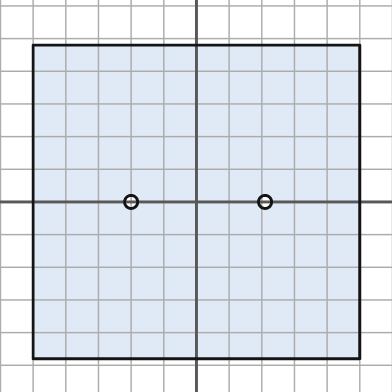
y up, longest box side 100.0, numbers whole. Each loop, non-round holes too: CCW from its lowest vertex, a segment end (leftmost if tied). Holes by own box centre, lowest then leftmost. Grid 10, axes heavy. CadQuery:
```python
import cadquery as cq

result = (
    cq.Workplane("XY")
    .moveTo(-50.0, -48.0)
    .lineTo(50.0, -48.0)
    .lineTo(50.0, 48.0)
    .lineTo(-50.0, 48.0)
    .close()
    .moveTo(-20.0, 0.0)
    .circle(2.0)
    .moveTo(21.0, 0.0)
    .circle(2.0)
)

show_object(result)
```